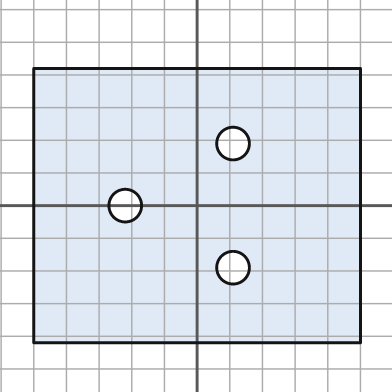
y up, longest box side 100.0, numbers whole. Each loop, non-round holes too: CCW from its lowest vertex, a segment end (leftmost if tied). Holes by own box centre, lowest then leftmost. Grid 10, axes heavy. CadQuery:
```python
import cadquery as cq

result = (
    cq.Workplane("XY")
    .moveTo(-50.0, -42.0)
    .lineTo(50.0, -42.0)
    .lineTo(50.0, 42.0)
    .lineTo(-50.0, 42.0)
    .close()
    .moveTo(11.0, -19.0)
    .circle(5.0)
    .moveTo(-22.0, 0.0)
    .circle(5.0)
    .moveTo(11.0, 19.0)
    .circle(5.0)
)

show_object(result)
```